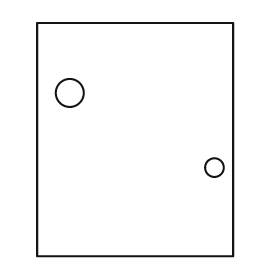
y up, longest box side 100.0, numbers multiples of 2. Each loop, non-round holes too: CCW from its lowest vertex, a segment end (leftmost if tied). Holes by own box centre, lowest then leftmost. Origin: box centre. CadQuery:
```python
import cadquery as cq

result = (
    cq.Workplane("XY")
    .moveTo(-42.0, -50.0)
    .lineTo(42.0, -50.0)
    .lineTo(42.0, 50.0)
    .lineTo(-42.0, 50.0)
    .close()
    .moveTo(34.0, -12.0)
    .circle(4.0)
    .moveTo(-28.0, 20.0)
    .circle(6.0)
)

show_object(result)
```